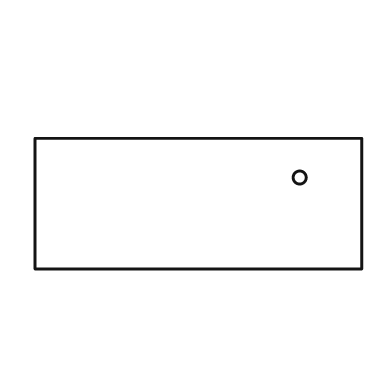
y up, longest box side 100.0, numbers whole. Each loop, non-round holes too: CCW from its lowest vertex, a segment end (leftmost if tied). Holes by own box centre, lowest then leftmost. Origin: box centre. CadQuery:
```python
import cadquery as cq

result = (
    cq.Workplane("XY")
    .moveTo(-50.0, -20.0)
    .lineTo(50.0, -20.0)
    .lineTo(50.0, 20.0)
    .lineTo(-50.0, 20.0)
    .close()
    .moveTo(31.0, 8.0)
    .circle(2.0)
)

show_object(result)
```